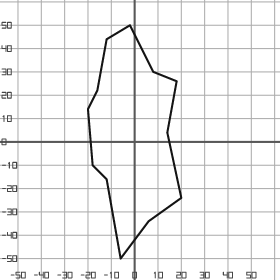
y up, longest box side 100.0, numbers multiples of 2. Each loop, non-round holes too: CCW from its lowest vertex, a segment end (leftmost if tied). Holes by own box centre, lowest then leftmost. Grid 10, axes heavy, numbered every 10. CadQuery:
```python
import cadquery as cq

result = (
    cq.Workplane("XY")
    .moveTo(-6.0, -50.0)
    .lineTo(6.0, -34.0)
    .lineTo(20.0, -24.0)
    .lineTo(14.0, 4.0)
    .lineTo(18.0, 26.0)
    .lineTo(8.0, 30.0)
    .lineTo(-2.0, 50.0)
    .lineTo(-12.0, 44.0)
    .lineTo(-16.0, 22.0)
    .lineTo(-20.0, 14.0)
    .lineTo(-18.0, -10.0)
    .lineTo(-12.0, -16.0)
    .close()
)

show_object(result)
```